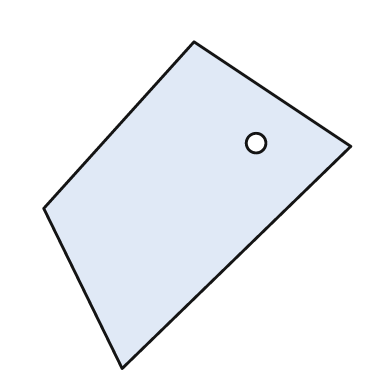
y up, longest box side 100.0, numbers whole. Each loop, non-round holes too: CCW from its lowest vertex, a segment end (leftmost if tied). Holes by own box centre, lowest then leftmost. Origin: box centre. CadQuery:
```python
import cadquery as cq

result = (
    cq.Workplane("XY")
    .moveTo(-23.0, -50.0)
    .lineTo(47.0, 18.0)
    .lineTo(-1.0, 50.0)
    .lineTo(-47.0, -1.0)
    .close()
    .moveTo(18.0, 19.0)
    .circle(3.0)
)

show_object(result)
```